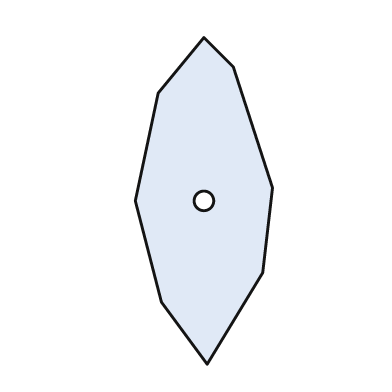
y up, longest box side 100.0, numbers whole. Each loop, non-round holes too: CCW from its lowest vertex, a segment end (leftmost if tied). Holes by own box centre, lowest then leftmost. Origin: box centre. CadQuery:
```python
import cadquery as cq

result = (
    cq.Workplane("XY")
    .moveTo(1.0, -50.0)
    .lineTo(18.0, -22.0)
    .lineTo(21.0, 4.0)
    .lineTo(9.0, 41.0)
    .lineTo(0.0, 50.0)
    .lineTo(-14.0, 33.0)
    .lineTo(-21.0, 0.0)
    .lineTo(-13.0, -31.0)
    .close()
    .moveTo(0.0, 0.0)
    .circle(3.0)
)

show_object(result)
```